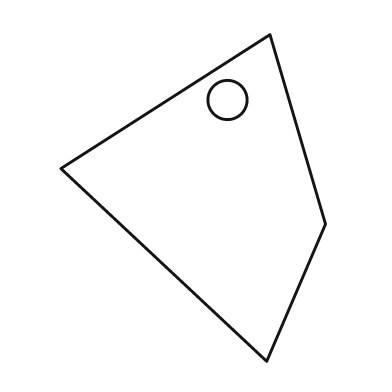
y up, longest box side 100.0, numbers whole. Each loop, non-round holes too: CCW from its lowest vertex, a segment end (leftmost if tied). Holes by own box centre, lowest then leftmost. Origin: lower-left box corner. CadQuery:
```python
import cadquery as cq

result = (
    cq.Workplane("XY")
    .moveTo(63.0, 0.0)
    .lineTo(81.0, 42.0)
    .lineTo(64.0, 100.0)
    .lineTo(0.0, 59.0)
    .close()
    .moveTo(51.0, 80.0)
    .circle(6.0)
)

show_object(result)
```